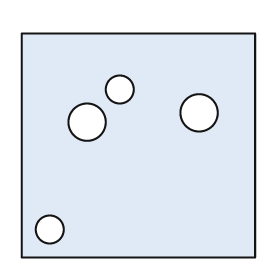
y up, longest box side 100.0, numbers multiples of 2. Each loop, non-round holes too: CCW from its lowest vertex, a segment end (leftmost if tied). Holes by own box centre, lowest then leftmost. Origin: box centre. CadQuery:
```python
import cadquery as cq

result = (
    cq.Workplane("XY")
    .moveTo(-50.0, -48.0)
    .lineTo(50.0, -48.0)
    .lineTo(50.0, 48.0)
    .lineTo(-50.0, 48.0)
    .close()
    .moveTo(-38.0, -36.0)
    .circle(6.0)
    .moveTo(-22.0, 10.0)
    .circle(8.0)
    .moveTo(26.0, 14.0)
    .circle(8.0)
    .moveTo(-8.0, 24.0)
    .circle(6.0)
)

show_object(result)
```